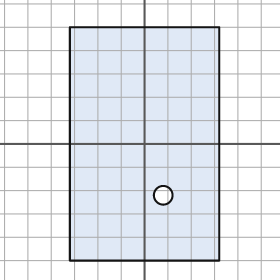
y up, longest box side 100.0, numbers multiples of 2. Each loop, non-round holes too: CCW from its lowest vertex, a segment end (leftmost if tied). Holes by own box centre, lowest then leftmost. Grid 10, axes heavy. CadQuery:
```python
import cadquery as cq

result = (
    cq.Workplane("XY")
    .moveTo(-32.0, -50.0)
    .lineTo(32.0, -50.0)
    .lineTo(32.0, 50.0)
    .lineTo(-32.0, 50.0)
    .close()
    .moveTo(8.0, -22.0)
    .circle(4.0)
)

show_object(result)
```